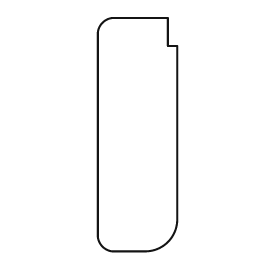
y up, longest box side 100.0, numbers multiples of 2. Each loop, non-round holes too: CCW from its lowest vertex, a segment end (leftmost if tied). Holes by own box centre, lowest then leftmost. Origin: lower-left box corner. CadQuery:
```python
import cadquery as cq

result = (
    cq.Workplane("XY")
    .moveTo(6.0, 0.0)
    .lineTo(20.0, 0.0)
    .threePointArc((30.0, 4.0), (34.0, 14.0))
    .lineTo(34.0, 88.0)
    .lineTo(30.0, 88.0)
    .lineTo(30.0, 100.0)
    .lineTo(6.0, 100.0)
    .threePointArc((2.0, 98.0), (0.0, 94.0))
    .lineTo(0.0, 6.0)
    .threePointArc((2.0, 2.0), (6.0, 0.0))
    .close()
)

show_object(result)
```